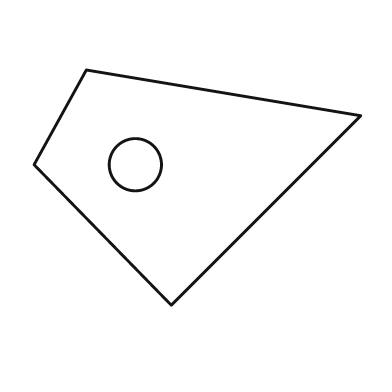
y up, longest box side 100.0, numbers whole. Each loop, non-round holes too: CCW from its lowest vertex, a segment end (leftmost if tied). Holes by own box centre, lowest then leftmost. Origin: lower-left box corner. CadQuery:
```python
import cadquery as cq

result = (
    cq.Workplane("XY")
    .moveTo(42.0, 0.0)
    .lineTo(100.0, 58.0)
    .lineTo(16.0, 72.0)
    .lineTo(0.0, 43.0)
    .close()
    .moveTo(31.0, 43.0)
    .circle(8.0)
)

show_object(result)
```